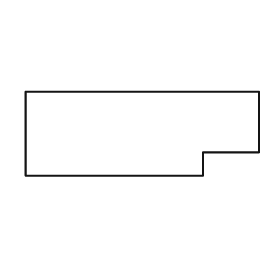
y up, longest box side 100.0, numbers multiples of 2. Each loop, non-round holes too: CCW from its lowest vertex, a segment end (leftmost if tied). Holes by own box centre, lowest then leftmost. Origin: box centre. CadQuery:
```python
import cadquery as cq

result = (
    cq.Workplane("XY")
    .moveTo(-50.0, -18.0)
    .lineTo(26.0, -18.0)
    .lineTo(26.0, -8.0)
    .lineTo(50.0, -8.0)
    .lineTo(50.0, 18.0)
    .lineTo(-50.0, 18.0)
    .close()
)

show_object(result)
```